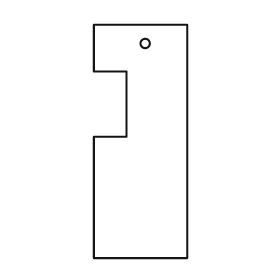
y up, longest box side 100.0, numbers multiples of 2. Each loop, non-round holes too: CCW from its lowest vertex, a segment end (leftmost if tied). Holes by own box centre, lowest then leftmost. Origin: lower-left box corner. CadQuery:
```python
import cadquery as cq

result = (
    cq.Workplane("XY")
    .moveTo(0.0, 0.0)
    .lineTo(40.0, 0.0)
    .lineTo(40.0, 100.0)
    .lineTo(0.0, 100.0)
    .lineTo(0.0, 80.0)
    .lineTo(14.0, 80.0)
    .lineTo(14.0, 52.0)
    .lineTo(0.0, 52.0)
    .close()
    .moveTo(22.0, 92.0)
    .circle(2.0)
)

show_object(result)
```